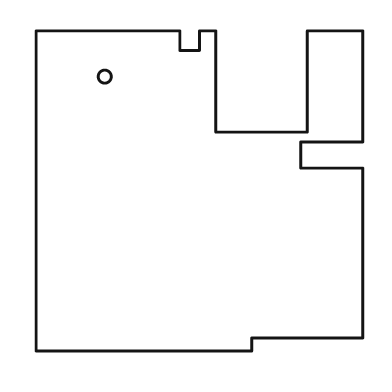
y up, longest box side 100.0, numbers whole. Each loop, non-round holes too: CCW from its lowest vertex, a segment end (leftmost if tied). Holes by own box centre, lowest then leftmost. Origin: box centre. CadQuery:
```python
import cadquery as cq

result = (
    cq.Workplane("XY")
    .moveTo(-50.0, -49.0)
    .lineTo(16.0, -49.0)
    .lineTo(16.0, -45.0)
    .lineTo(50.0, -45.0)
    .lineTo(50.0, 7.0)
    .lineTo(31.0, 7.0)
    .lineTo(31.0, 15.0)
    .lineTo(50.0, 15.0)
    .lineTo(50.0, 49.0)
    .lineTo(33.0, 49.0)
    .lineTo(33.0, 18.0)
    .lineTo(5.0, 18.0)
    .lineTo(5.0, 49.0)
    .lineTo(0.0, 49.0)
    .lineTo(0.0, 43.0)
    .lineTo(-6.0, 43.0)
    .lineTo(-6.0, 49.0)
    .lineTo(-50.0, 49.0)
    .close()
    .moveTo(-29.0, 35.0)
    .circle(2.0)
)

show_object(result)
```